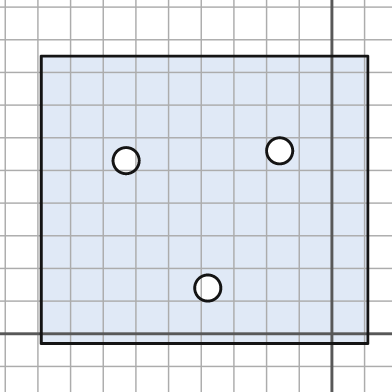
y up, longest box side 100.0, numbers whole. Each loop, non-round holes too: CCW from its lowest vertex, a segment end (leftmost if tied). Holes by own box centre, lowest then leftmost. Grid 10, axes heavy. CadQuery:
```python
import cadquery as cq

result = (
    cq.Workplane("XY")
    .moveTo(-89.0, -3.0)
    .lineTo(11.0, -3.0)
    .lineTo(11.0, 85.0)
    .lineTo(-89.0, 85.0)
    .close()
    .moveTo(-38.0, 14.0)
    .circle(4.0)
    .moveTo(-63.0, 53.0)
    .circle(4.0)
    .moveTo(-16.0, 56.0)
    .circle(4.0)
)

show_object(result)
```